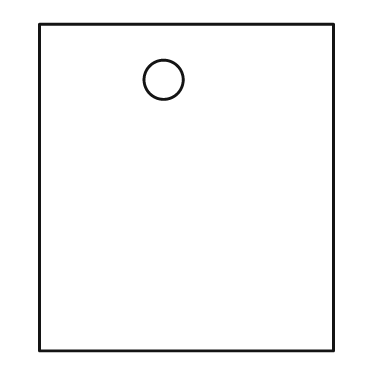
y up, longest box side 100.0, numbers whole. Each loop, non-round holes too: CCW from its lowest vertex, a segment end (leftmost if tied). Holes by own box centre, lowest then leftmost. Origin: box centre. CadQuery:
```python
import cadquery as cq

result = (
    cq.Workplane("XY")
    .moveTo(-45.0, -50.0)
    .lineTo(45.0, -50.0)
    .lineTo(45.0, 50.0)
    .lineTo(-45.0, 50.0)
    .close()
    .moveTo(-7.0, 33.0)
    .circle(6.0)
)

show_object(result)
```